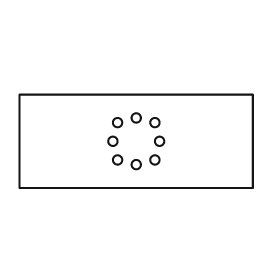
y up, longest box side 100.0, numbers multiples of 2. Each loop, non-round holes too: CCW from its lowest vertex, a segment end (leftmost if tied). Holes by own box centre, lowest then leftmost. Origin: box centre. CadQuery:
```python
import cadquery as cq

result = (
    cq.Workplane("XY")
    .moveTo(-50.0, -20.0)
    .lineTo(50.0, -20.0)
    .lineTo(50.0, 20.0)
    .lineTo(-50.0, 20.0)
    .close()
    .moveTo(0.0, -10.0)
    .circle(2.0)
    .moveTo(-8.0, -8.0)
    .circle(2.0)
    .moveTo(8.0, -8.0)
    .circle(2.0)
    .moveTo(-10.0, 0.0)
    .circle(2.0)
    .moveTo(10.0, 0.0)
    .circle(2.0)
    .moveTo(-8.0, 8.0)
    .circle(2.0)
    .moveTo(8.0, 8.0)
    .circle(2.0)
    .moveTo(0.0, 10.0)
    .circle(2.0)
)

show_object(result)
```